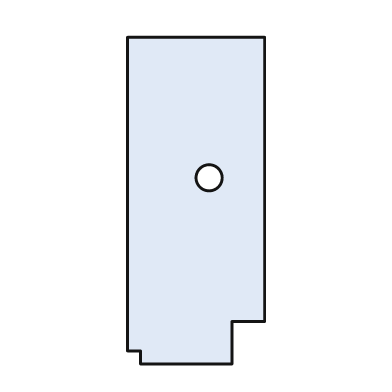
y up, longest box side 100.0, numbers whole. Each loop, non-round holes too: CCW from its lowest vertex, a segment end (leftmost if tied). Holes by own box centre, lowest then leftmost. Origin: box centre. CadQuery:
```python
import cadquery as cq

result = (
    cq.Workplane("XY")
    .moveTo(-17.0, -50.0)
    .lineTo(11.0, -50.0)
    .lineTo(11.0, -37.0)
    .lineTo(21.0, -37.0)
    .lineTo(21.0, 50.0)
    .lineTo(-21.0, 50.0)
    .lineTo(-21.0, -46.0)
    .lineTo(-17.0, -46.0)
    .close()
    .moveTo(4.0, 7.0)
    .circle(4.0)
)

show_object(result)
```